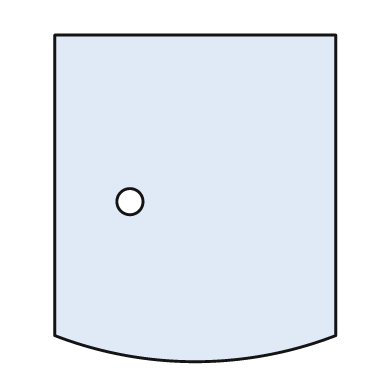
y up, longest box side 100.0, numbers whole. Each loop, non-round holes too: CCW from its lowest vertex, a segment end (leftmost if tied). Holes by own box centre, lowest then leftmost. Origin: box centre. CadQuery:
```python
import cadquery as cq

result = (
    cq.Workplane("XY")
    .moveTo(-43.0, -42.0)
    .threePointArc((0.0, -50.0), (43.0, -42.0))
    .lineTo(43.0, 50.0)
    .lineTo(-43.0, 50.0)
    .close()
    .moveTo(-20.0, -1.0)
    .circle(4.0)
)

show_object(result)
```